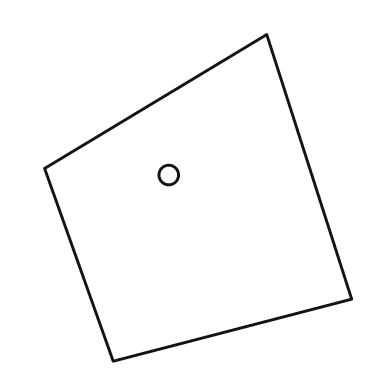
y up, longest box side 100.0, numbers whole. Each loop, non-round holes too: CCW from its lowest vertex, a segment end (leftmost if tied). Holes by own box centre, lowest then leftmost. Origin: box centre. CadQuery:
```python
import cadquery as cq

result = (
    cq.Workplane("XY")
    .moveTo(-26.0, -50.0)
    .lineTo(47.0, -31.0)
    .lineTo(21.0, 50.0)
    .lineTo(-47.0, 9.0)
    .close()
    .moveTo(-9.0, 7.0)
    .circle(3.0)
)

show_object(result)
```